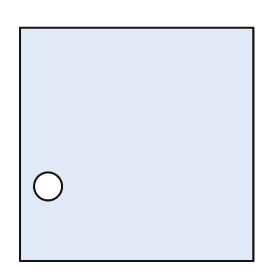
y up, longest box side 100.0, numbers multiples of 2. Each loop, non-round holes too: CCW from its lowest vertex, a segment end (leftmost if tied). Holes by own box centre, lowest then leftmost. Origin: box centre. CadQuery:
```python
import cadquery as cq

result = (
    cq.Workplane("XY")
    .moveTo(-50.0, -50.0)
    .lineTo(50.0, -50.0)
    .lineTo(50.0, 50.0)
    .lineTo(-50.0, 50.0)
    .close()
    .moveTo(-38.0, -18.0)
    .circle(6.0)
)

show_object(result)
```